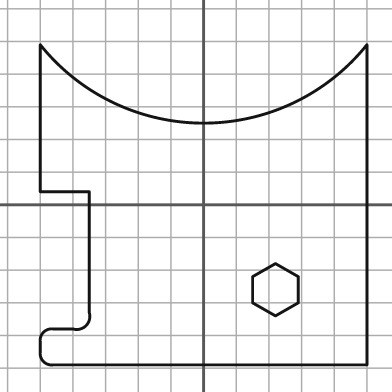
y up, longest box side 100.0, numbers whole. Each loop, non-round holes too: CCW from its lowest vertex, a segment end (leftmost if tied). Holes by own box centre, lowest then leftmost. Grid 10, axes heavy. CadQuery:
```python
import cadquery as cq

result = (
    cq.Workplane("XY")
    .moveTo(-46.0, -49.0)
    .lineTo(50.0, -49.0)
    .lineTo(50.0, 49.0)
    .threePointArc((0.0, 25.0), (-50.0, 49.0))
    .lineTo(-50.0, 4.0)
    .lineTo(-35.0, 4.0)
    .lineTo(-35.0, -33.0)
    .threePointArc((-36.0, -37.0), (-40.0, -38.0))
    .lineTo(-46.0, -38.0)
    .threePointArc((-49.0, -39.0), (-50.0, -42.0))
    .lineTo(-50.0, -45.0)
    .threePointArc((-49.0, -48.0), (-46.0, -49.0))
    .close()
    .moveTo(22.0, -34.0)
    .lineTo(29.0, -30.0)
    .lineTo(29.0, -22.0)
    .lineTo(22.0, -18.0)
    .lineTo(15.0, -22.0)
    .lineTo(15.0, -30.0)
    .close()
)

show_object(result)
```